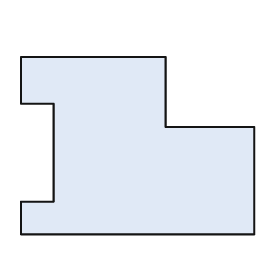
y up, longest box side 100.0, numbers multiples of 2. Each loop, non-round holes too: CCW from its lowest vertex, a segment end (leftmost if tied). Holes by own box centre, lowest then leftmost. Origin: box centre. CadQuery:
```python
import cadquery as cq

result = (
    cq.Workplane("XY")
    .moveTo(-50.0, -38.0)
    .lineTo(50.0, -38.0)
    .lineTo(50.0, 8.0)
    .lineTo(12.0, 8.0)
    .lineTo(12.0, 38.0)
    .lineTo(-50.0, 38.0)
    .lineTo(-50.0, 18.0)
    .lineTo(-36.0, 18.0)
    .lineTo(-36.0, -24.0)
    .lineTo(-50.0, -24.0)
    .close()
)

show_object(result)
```